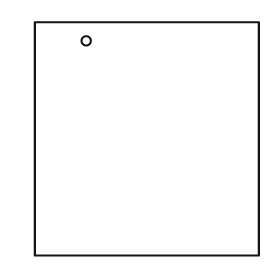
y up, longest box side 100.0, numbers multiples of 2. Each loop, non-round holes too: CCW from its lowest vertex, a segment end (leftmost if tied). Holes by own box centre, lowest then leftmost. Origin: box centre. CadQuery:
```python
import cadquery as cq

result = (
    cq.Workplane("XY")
    .moveTo(-48.0, -50.0)
    .lineTo(48.0, -50.0)
    .lineTo(48.0, 50.0)
    .lineTo(-48.0, 50.0)
    .close()
    .moveTo(-26.0, 42.0)
    .circle(2.0)
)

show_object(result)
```